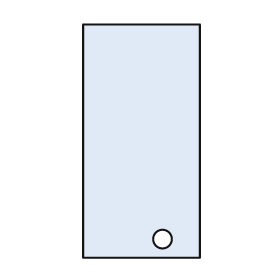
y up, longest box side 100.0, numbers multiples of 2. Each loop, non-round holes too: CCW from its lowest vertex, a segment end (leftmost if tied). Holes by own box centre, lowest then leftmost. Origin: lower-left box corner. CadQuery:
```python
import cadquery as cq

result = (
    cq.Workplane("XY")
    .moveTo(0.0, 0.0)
    .lineTo(50.0, 0.0)
    .lineTo(50.0, 100.0)
    .lineTo(0.0, 100.0)
    .close()
    .moveTo(34.0, 8.0)
    .circle(4.0)
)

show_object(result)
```